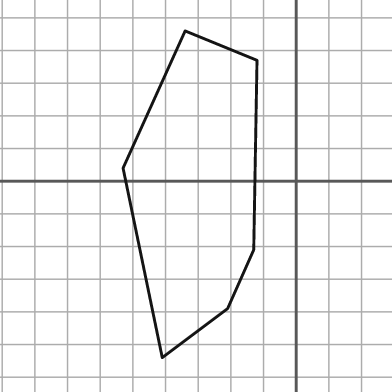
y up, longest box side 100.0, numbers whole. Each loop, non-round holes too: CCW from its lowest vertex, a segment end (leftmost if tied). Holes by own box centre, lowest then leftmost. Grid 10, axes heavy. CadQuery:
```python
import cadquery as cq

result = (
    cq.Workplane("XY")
    .moveTo(-41.0, -54.0)
    .lineTo(-21.0, -39.0)
    .lineTo(-13.0, -21.0)
    .lineTo(-12.0, 37.0)
    .lineTo(-34.0, 46.0)
    .lineTo(-53.0, 4.0)
    .close()
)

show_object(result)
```